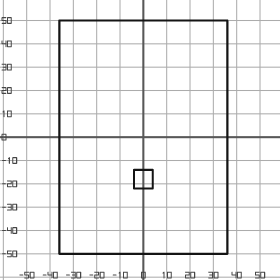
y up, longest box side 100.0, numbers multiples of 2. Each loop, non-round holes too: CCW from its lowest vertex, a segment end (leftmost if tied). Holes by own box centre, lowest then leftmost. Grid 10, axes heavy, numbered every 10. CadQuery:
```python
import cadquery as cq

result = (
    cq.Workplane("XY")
    .moveTo(-36.0, -50.0)
    .lineTo(36.0, -50.0)
    .lineTo(36.0, 50.0)
    .lineTo(-36.0, 50.0)
    .close()
    .moveTo(-4.0, -22.0)
    .lineTo(4.0, -22.0)
    .lineTo(4.0, -14.0)
    .lineTo(-4.0, -14.0)
    .close()
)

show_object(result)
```